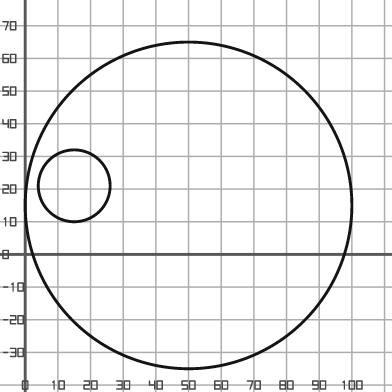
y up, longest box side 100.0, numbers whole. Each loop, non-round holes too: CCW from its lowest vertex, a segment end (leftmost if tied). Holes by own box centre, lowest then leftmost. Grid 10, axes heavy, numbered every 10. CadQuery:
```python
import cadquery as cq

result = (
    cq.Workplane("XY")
    .moveTo(50.0, 15.0)
    .circle(50.0)
    .moveTo(15.0, 21.0)
    .circle(11.0)
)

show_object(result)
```